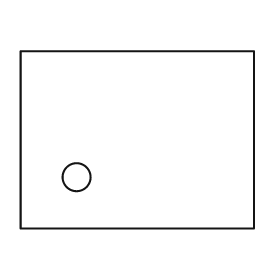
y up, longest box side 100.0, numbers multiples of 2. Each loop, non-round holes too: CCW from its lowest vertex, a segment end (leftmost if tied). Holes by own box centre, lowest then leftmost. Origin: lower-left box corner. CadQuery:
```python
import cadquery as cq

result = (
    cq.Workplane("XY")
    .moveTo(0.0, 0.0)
    .lineTo(100.0, 0.0)
    .lineTo(100.0, 76.0)
    .lineTo(0.0, 76.0)
    .close()
    .moveTo(24.0, 22.0)
    .circle(6.0)
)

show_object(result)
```